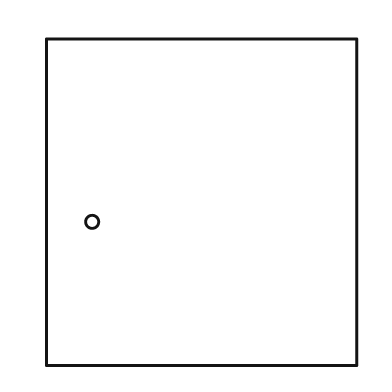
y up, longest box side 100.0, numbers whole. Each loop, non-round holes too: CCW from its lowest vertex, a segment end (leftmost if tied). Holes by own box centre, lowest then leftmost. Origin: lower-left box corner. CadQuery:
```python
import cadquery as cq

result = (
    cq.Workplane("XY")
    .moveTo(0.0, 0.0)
    .lineTo(95.0, 0.0)
    .lineTo(95.0, 100.0)
    .lineTo(0.0, 100.0)
    .close()
    .moveTo(14.0, 44.0)
    .circle(2.0)
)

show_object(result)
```